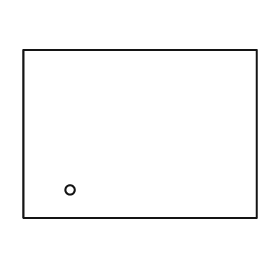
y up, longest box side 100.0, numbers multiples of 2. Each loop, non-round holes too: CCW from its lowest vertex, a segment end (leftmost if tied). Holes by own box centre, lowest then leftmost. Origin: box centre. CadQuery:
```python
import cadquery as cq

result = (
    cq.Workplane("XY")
    .moveTo(-50.0, -36.0)
    .lineTo(50.0, -36.0)
    .lineTo(50.0, 36.0)
    .lineTo(-50.0, 36.0)
    .close()
    .moveTo(-30.0, -24.0)
    .circle(2.0)
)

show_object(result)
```